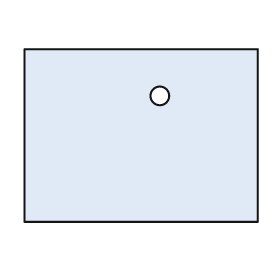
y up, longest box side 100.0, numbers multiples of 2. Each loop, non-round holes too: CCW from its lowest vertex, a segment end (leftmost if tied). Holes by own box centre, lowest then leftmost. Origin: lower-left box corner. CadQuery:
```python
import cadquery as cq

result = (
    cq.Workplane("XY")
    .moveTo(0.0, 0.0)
    .lineTo(100.0, 0.0)
    .lineTo(100.0, 74.0)
    .lineTo(0.0, 74.0)
    .close()
    .moveTo(58.0, 54.0)
    .circle(4.0)
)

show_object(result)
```